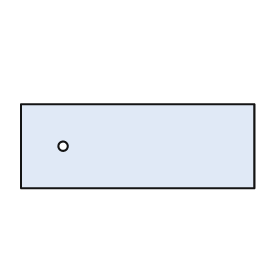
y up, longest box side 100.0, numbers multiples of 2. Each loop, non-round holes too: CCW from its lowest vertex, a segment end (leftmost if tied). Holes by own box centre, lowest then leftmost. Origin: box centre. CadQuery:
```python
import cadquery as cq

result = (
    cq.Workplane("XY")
    .moveTo(-50.0, -18.0)
    .lineTo(50.0, -18.0)
    .lineTo(50.0, 18.0)
    .lineTo(-50.0, 18.0)
    .close()
    .moveTo(-32.0, 0.0)
    .circle(2.0)
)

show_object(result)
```